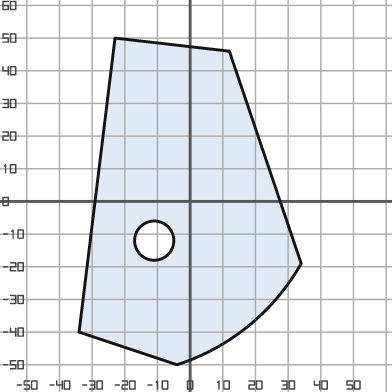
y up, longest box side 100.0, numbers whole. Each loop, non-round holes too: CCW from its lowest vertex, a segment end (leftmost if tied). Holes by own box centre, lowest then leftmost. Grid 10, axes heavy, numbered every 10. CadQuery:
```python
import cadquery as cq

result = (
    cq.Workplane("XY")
    .moveTo(-4.0, -50.0)
    .threePointArc((18.0, -38.0), (34.0, -19.0))
    .lineTo(12.0, 46.0)
    .lineTo(-23.0, 50.0)
    .lineTo(-34.0, -40.0)
    .close()
    .moveTo(-11.0, -12.0)
    .circle(6.0)
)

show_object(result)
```